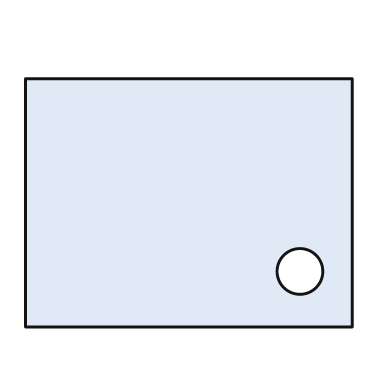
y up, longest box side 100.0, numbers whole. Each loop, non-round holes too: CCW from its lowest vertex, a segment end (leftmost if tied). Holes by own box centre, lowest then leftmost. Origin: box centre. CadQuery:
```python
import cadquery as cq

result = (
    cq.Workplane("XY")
    .moveTo(-50.0, -38.0)
    .lineTo(50.0, -38.0)
    .lineTo(50.0, 38.0)
    .lineTo(-50.0, 38.0)
    .close()
    .moveTo(34.0, -21.0)
    .circle(7.0)
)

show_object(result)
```